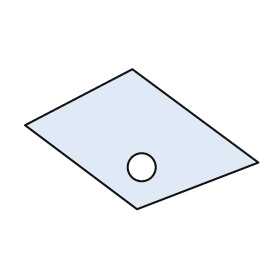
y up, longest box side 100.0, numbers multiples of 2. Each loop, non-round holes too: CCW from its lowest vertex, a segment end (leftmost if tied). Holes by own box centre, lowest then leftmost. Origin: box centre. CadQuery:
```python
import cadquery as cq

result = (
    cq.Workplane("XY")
    .moveTo(-2.0, -30.0)
    .lineTo(50.0, -10.0)
    .lineTo(-4.0, 30.0)
    .lineTo(-50.0, 6.0)
    .close()
    .moveTo(0.0, -12.0)
    .circle(6.0)
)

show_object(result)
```